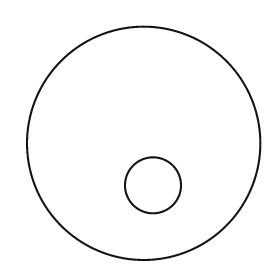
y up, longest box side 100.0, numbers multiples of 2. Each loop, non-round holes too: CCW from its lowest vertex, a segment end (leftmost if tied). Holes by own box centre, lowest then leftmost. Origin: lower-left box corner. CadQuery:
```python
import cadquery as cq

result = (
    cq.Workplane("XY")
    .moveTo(50.0, 50.0)
    .circle(50.0)
    .moveTo(54.0, 32.0)
    .circle(12.0)
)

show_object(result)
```